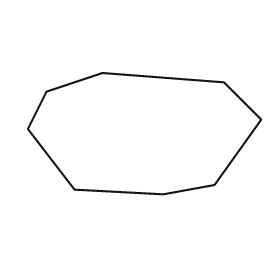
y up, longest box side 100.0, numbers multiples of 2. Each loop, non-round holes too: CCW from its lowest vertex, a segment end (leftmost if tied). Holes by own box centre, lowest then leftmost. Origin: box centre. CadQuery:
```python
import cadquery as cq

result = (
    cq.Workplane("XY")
    .moveTo(8.0, -26.0)
    .lineTo(30.0, -22.0)
    .lineTo(50.0, 6.0)
    .lineTo(34.0, 22.0)
    .lineTo(-18.0, 26.0)
    .lineTo(-42.0, 18.0)
    .lineTo(-50.0, 2.0)
    .lineTo(-30.0, -24.0)
    .close()
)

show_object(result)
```